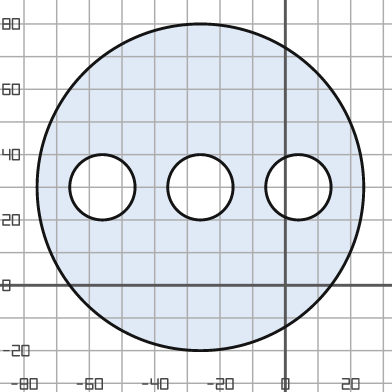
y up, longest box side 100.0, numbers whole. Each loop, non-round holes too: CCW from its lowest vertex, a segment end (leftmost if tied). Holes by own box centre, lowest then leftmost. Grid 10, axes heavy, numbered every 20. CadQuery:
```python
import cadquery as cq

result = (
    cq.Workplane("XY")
    .moveTo(-26.0, 30.0)
    .circle(50.0)
    .moveTo(-56.0, 30.0)
    .circle(10.0)
    .moveTo(-26.0, 30.0)
    .circle(10.0)
    .moveTo(4.0, 30.0)
    .circle(10.0)
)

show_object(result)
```